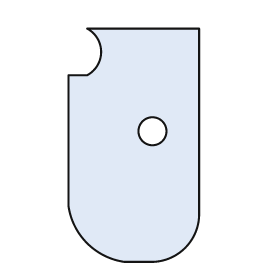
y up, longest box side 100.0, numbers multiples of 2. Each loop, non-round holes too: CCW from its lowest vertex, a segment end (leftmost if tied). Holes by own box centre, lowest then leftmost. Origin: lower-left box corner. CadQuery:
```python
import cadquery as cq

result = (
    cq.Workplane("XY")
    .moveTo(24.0, 0.0)
    .lineTo(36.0, 0.0)
    .threePointArc((50.0, 6.0), (56.0, 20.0))
    .lineTo(56.0, 100.0)
    .lineTo(8.0, 100.0)
    .threePointArc((14.0, 90.0), (8.0, 80.0))
    .lineTo(0.0, 80.0)
    .lineTo(0.0, 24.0)
    .threePointArc((8.0, 8.0), (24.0, 0.0))
    .close()
    .moveTo(36.0, 56.0)
    .circle(6.0)
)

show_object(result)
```